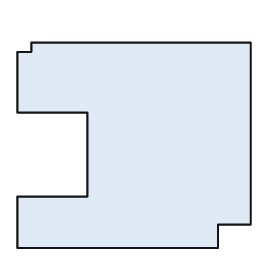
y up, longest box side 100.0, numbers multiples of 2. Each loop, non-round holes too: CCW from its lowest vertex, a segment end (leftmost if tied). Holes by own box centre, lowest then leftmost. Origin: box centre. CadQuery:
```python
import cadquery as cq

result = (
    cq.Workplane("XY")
    .moveTo(-50.0, -44.0)
    .lineTo(36.0, -44.0)
    .lineTo(36.0, -34.0)
    .lineTo(50.0, -34.0)
    .lineTo(50.0, 44.0)
    .lineTo(-44.0, 44.0)
    .lineTo(-44.0, 40.0)
    .lineTo(-50.0, 40.0)
    .lineTo(-50.0, 14.0)
    .lineTo(-20.0, 14.0)
    .lineTo(-20.0, -22.0)
    .lineTo(-50.0, -22.0)
    .close()
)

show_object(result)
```